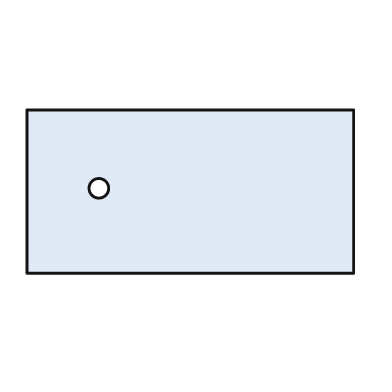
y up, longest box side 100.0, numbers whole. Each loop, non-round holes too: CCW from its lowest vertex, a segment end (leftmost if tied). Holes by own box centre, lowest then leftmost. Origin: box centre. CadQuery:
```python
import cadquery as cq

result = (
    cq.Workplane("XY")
    .moveTo(-50.0, -25.0)
    .lineTo(50.0, -25.0)
    .lineTo(50.0, 25.0)
    .lineTo(-50.0, 25.0)
    .close()
    .moveTo(-28.0, 1.0)
    .circle(3.0)
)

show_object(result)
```